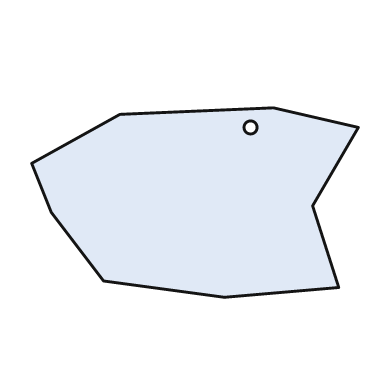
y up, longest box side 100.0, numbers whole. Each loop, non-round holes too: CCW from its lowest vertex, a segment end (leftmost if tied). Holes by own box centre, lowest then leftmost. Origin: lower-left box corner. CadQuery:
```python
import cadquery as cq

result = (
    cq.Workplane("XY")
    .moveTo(59.0, 0.0)
    .lineTo(94.0, 3.0)
    .lineTo(86.0, 28.0)
    .lineTo(100.0, 52.0)
    .lineTo(74.0, 58.0)
    .lineTo(27.0, 56.0)
    .lineTo(0.0, 41.0)
    .lineTo(6.0, 26.0)
    .lineTo(22.0, 5.0)
    .close()
    .moveTo(67.0, 52.0)
    .circle(2.0)
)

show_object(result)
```